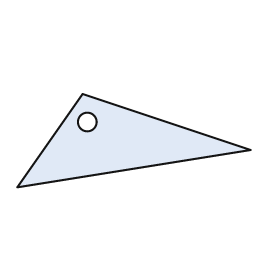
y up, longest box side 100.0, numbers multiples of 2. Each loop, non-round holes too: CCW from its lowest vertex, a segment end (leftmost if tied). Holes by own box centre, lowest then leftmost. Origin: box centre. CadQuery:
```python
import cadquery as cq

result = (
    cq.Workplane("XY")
    .moveTo(-50.0, -20.0)
    .lineTo(50.0, -4.0)
    .lineTo(-22.0, 20.0)
    .close()
    .moveTo(-20.0, 8.0)
    .circle(4.0)
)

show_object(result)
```